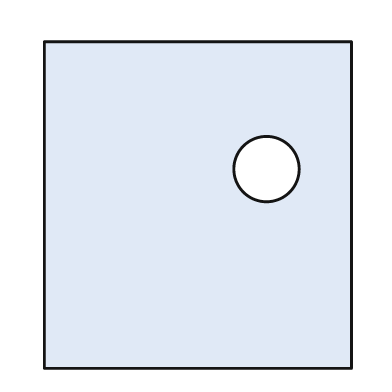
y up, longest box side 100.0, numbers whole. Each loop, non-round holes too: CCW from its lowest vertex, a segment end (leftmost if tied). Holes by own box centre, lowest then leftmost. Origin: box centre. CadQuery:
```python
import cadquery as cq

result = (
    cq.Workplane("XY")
    .moveTo(-47.0, -50.0)
    .lineTo(47.0, -50.0)
    .lineTo(47.0, 50.0)
    .lineTo(-47.0, 50.0)
    .close()
    .moveTo(21.0, 11.0)
    .circle(10.0)
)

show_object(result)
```